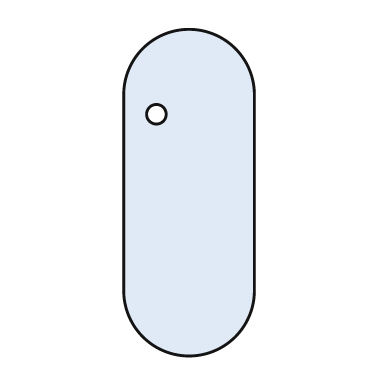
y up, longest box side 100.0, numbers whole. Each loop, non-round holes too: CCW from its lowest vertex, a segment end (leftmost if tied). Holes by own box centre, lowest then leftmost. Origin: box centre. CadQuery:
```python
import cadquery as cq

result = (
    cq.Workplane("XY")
    .moveTo(-20.0, -30.0)
    .threePointArc((0.0, -50.0), (20.0, -30.0))
    .lineTo(20.0, 30.0)
    .threePointArc((0.0, 50.0), (-20.0, 30.0))
    .close()
    .moveTo(-10.0, 24.0)
    .circle(3.0)
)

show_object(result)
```